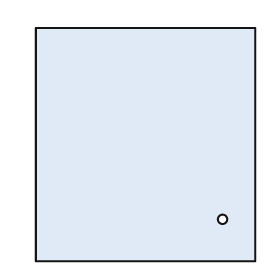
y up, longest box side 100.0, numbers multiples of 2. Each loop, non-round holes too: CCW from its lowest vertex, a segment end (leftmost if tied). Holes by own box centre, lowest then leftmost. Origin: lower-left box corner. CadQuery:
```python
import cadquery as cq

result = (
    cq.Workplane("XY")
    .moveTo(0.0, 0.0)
    .lineTo(94.0, 0.0)
    .lineTo(94.0, 100.0)
    .lineTo(0.0, 100.0)
    .close()
    .moveTo(80.0, 18.0)
    .circle(2.0)
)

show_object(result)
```